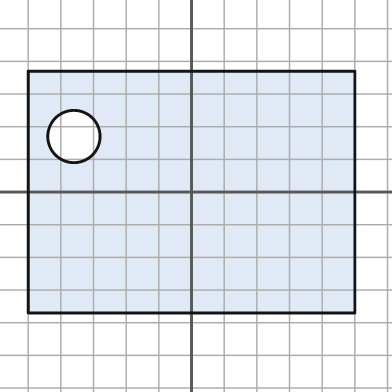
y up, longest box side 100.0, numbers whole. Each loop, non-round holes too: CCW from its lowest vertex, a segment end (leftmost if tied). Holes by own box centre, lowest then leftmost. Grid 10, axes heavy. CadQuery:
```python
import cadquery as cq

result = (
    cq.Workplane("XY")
    .moveTo(-50.0, -37.0)
    .lineTo(50.0, -37.0)
    .lineTo(50.0, 37.0)
    .lineTo(-50.0, 37.0)
    .close()
    .moveTo(-36.0, 17.0)
    .circle(8.0)
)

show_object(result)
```